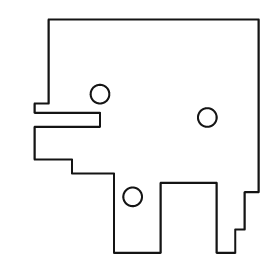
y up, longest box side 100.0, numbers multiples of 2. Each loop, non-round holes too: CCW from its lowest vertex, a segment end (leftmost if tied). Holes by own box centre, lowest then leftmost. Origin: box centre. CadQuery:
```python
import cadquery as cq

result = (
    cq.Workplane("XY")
    .moveTo(-14.0, -50.0)
    .lineTo(6.0, -50.0)
    .lineTo(6.0, -20.0)
    .lineTo(30.0, -20.0)
    .lineTo(30.0, -50.0)
    .lineTo(38.0, -50.0)
    .lineTo(38.0, -40.0)
    .lineTo(42.0, -40.0)
    .lineTo(42.0, -24.0)
    .lineTo(48.0, -24.0)
    .lineTo(48.0, 50.0)
    .lineTo(-42.0, 50.0)
    .lineTo(-42.0, 14.0)
    .lineTo(-48.0, 14.0)
    .lineTo(-48.0, 10.0)
    .lineTo(-20.0, 10.0)
    .lineTo(-20.0, 4.0)
    .lineTo(-48.0, 4.0)
    .lineTo(-48.0, -10.0)
    .lineTo(-32.0, -10.0)
    .lineTo(-32.0, -16.0)
    .lineTo(-14.0, -16.0)
    .close()
    .moveTo(-6.0, -26.0)
    .circle(4.0)
    .moveTo(26.0, 8.0)
    .circle(4.0)
    .moveTo(-20.0, 18.0)
    .circle(4.0)
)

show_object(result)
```